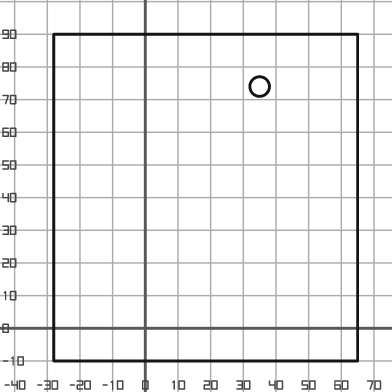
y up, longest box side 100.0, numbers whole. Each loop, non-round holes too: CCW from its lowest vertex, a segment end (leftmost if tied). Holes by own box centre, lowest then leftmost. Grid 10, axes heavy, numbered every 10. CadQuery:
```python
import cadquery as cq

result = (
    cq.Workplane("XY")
    .moveTo(-28.0, -10.0)
    .lineTo(65.0, -10.0)
    .lineTo(65.0, 90.0)
    .lineTo(-28.0, 90.0)
    .close()
    .moveTo(35.0, 74.0)
    .circle(3.0)
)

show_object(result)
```